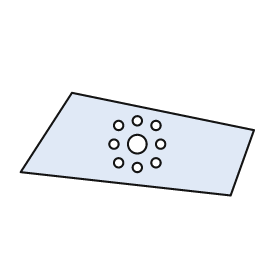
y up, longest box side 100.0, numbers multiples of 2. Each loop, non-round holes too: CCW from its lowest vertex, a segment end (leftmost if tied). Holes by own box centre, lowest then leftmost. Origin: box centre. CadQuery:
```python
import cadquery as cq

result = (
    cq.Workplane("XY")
    .moveTo(40.0, -22.0)
    .lineTo(50.0, 6.0)
    .lineTo(-28.0, 22.0)
    .lineTo(-50.0, -12.0)
    .close()
    .moveTo(0.0, -10.0)
    .circle(2.0)
    .moveTo(-8.0, -8.0)
    .circle(2.0)
    .moveTo(8.0, -8.0)
    .circle(2.0)
    .moveTo(-10.0, 0.0)
    .circle(2.0)
    .moveTo(0.0, 0.0)
    .circle(4.0)
    .moveTo(10.0, 0.0)
    .circle(2.0)
    .moveTo(-8.0, 8.0)
    .circle(2.0)
    .moveTo(8.0, 8.0)
    .circle(2.0)
    .moveTo(0.0, 10.0)
    .circle(2.0)
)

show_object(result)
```